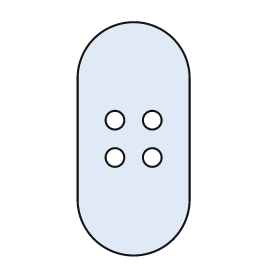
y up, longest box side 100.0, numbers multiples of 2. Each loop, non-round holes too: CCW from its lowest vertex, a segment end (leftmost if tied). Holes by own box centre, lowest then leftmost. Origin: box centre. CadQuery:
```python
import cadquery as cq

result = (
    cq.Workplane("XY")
    .moveTo(-24.0, -26.0)
    .threePointArc((0.0, -50.0), (24.0, -26.0))
    .lineTo(24.0, 26.0)
    .threePointArc((0.0, 50.0), (-24.0, 26.0))
    .close()
    .moveTo(-8.0, -8.0)
    .circle(4.0)
    .moveTo(8.0, -8.0)
    .circle(4.0)
    .moveTo(-8.0, 8.0)
    .circle(4.0)
    .moveTo(8.0, 8.0)
    .circle(4.0)
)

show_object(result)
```